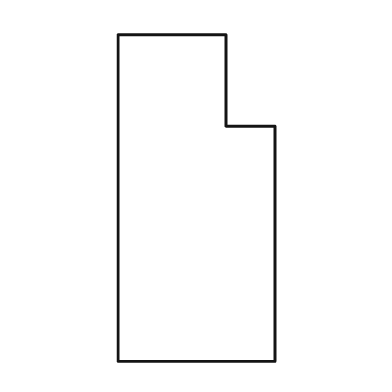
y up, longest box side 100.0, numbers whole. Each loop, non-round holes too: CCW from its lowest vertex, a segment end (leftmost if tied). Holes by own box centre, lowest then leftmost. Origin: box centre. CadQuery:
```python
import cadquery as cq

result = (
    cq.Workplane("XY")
    .moveTo(-24.0, -50.0)
    .lineTo(24.0, -50.0)
    .lineTo(24.0, 22.0)
    .lineTo(9.0, 22.0)
    .lineTo(9.0, 50.0)
    .lineTo(-24.0, 50.0)
    .close()
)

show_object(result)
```